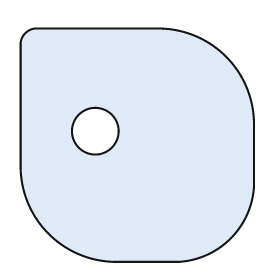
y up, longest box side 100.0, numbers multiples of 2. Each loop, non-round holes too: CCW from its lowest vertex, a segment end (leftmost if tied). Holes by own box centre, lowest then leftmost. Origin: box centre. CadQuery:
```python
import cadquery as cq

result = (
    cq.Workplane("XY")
    .moveTo(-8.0, -50.0)
    .lineTo(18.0, -50.0)
    .threePointArc((40.0, -40.0), (50.0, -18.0))
    .lineTo(50.0, 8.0)
    .threePointArc((38.0, 38.0), (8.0, 50.0))
    .lineTo(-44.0, 50.0)
    .threePointArc((-48.0, 48.0), (-50.0, 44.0))
    .lineTo(-50.0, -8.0)
    .threePointArc((-38.0, -38.0), (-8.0, -50.0))
    .close()
    .moveTo(-18.0, 6.0)
    .circle(10.0)
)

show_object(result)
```